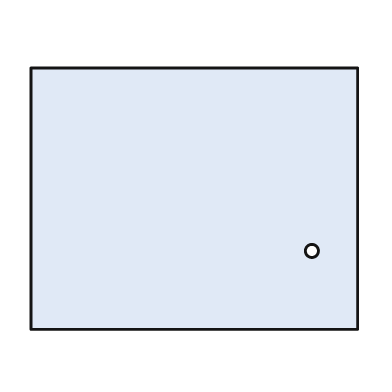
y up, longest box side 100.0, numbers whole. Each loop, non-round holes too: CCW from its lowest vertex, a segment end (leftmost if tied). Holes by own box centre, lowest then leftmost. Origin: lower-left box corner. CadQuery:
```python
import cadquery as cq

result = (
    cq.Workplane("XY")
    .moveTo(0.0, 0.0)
    .lineTo(100.0, 0.0)
    .lineTo(100.0, 80.0)
    .lineTo(0.0, 80.0)
    .close()
    .moveTo(86.0, 24.0)
    .circle(2.0)
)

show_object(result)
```